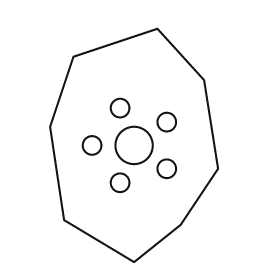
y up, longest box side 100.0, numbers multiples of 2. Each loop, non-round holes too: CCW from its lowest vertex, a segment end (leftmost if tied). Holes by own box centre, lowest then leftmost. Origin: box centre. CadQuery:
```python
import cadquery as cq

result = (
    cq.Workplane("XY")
    .moveTo(0.0, -50.0)
    .lineTo(20.0, -34.0)
    .lineTo(36.0, -10.0)
    .lineTo(30.0, 28.0)
    .lineTo(10.0, 50.0)
    .lineTo(-26.0, 38.0)
    .lineTo(-36.0, 8.0)
    .lineTo(-30.0, -32.0)
    .close()
    .moveTo(-6.0, -16.0)
    .circle(4.0)
    .moveTo(14.0, -10.0)
    .circle(4.0)
    .moveTo(-18.0, 0.0)
    .circle(4.0)
    .moveTo(0.0, 0.0)
    .circle(8.0)
    .moveTo(14.0, 10.0)
    .circle(4.0)
    .moveTo(-6.0, 16.0)
    .circle(4.0)
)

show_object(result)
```